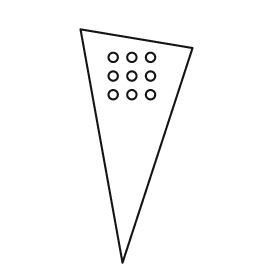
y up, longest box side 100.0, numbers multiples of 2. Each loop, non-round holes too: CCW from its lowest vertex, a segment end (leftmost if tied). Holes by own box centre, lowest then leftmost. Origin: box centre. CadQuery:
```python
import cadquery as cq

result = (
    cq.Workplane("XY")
    .moveTo(-6.0, -50.0)
    .lineTo(24.0, 42.0)
    .lineTo(-24.0, 50.0)
    .close()
    .moveTo(-10.0, 22.0)
    .circle(2.0)
    .moveTo(-2.0, 22.0)
    .circle(2.0)
    .moveTo(6.0, 22.0)
    .circle(2.0)
    .moveTo(-10.0, 30.0)
    .circle(2.0)
    .moveTo(-2.0, 30.0)
    .circle(2.0)
    .moveTo(6.0, 30.0)
    .circle(2.0)
    .moveTo(-10.0, 38.0)
    .circle(2.0)
    .moveTo(-2.0, 38.0)
    .circle(2.0)
    .moveTo(6.0, 38.0)
    .circle(2.0)
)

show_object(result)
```